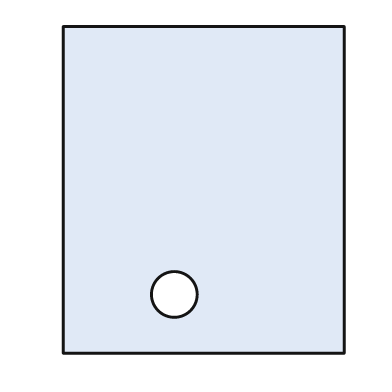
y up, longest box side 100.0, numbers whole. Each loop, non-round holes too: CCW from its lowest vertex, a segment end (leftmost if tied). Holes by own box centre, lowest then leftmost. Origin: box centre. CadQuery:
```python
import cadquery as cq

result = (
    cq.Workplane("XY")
    .moveTo(-43.0, -50.0)
    .lineTo(43.0, -50.0)
    .lineTo(43.0, 50.0)
    .lineTo(-43.0, 50.0)
    .close()
    .moveTo(-9.0, -32.0)
    .circle(7.0)
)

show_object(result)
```